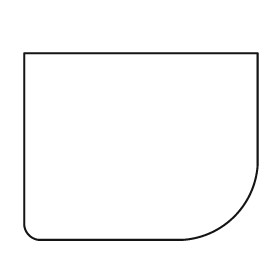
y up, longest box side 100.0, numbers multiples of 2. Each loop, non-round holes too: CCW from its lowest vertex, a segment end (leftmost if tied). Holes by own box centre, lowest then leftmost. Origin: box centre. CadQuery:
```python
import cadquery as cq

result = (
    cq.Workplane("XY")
    .moveTo(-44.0, -40.0)
    .lineTo(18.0, -40.0)
    .threePointArc((40.0, -30.0), (50.0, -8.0))
    .lineTo(50.0, 40.0)
    .lineTo(-50.0, 40.0)
    .lineTo(-50.0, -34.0)
    .threePointArc((-48.0, -38.0), (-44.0, -40.0))
    .close()
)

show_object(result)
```